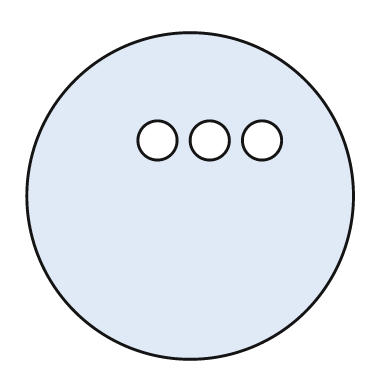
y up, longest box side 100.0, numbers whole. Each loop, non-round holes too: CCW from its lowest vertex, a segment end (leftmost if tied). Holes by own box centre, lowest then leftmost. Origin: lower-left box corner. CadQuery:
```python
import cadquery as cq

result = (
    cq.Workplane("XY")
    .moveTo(50.0, 50.0)
    .circle(50.0)
    .moveTo(40.0, 67.0)
    .circle(6.0)
    .moveTo(56.0, 67.0)
    .circle(6.0)
    .moveTo(72.0, 67.0)
    .circle(6.0)
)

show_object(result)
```